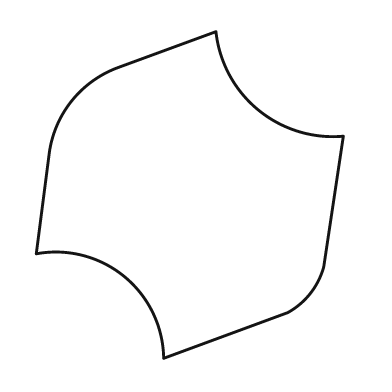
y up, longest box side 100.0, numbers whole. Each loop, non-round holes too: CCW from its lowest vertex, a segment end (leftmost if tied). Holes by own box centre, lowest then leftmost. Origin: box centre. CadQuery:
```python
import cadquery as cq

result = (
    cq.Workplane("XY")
    .moveTo(-8.0, -50.0)
    .lineTo(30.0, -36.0)
    .threePointArc((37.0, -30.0), (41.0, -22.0))
    .lineTo(47.0, 18.0)
    .threePointArc((21.0, 26.0), (8.0, 50.0))
    .lineTo(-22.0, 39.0)
    .threePointArc((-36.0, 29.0), (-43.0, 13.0))
    .lineTo(-47.0, -18.0)
    .threePointArc((-20.0, -25.0), (-8.0, -50.0))
    .close()
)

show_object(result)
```